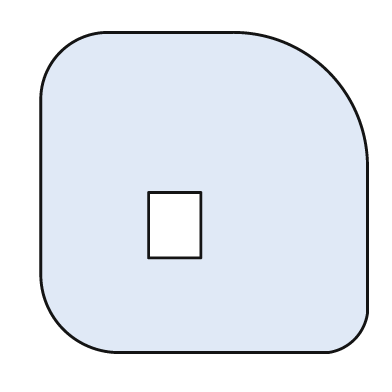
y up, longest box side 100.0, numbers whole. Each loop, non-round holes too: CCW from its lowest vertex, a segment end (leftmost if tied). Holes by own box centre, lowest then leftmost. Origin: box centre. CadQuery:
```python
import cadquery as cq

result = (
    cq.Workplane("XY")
    .moveTo(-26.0, -49.0)
    .lineTo(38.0, -49.0)
    .threePointArc((46.0, -45.0), (50.0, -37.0))
    .lineTo(50.0, 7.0)
    .threePointArc((38.0, 37.0), (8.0, 49.0))
    .lineTo(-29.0, 49.0)
    .threePointArc((-44.0, 43.0), (-50.0, 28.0))
    .lineTo(-50.0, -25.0)
    .threePointArc((-43.0, -42.0), (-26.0, -49.0))
    .close()
    .moveTo(-17.0, -20.0)
    .lineTo(-1.0, -20.0)
    .lineTo(-1.0, 0.0)
    .lineTo(-17.0, 0.0)
    .close()
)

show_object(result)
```